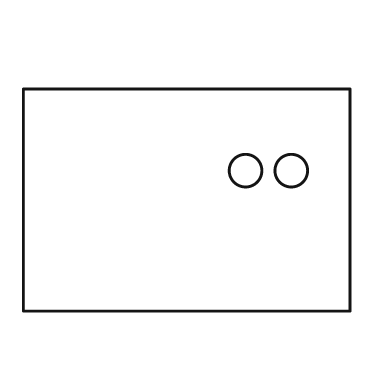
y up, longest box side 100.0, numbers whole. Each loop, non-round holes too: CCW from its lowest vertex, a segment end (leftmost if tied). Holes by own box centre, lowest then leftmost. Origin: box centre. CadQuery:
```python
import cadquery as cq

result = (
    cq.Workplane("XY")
    .moveTo(-50.0, -34.0)
    .lineTo(50.0, -34.0)
    .lineTo(50.0, 34.0)
    .lineTo(-50.0, 34.0)
    .close()
    .moveTo(18.0, 9.0)
    .circle(5.0)
    .moveTo(32.0, 9.0)
    .circle(5.0)
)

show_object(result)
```